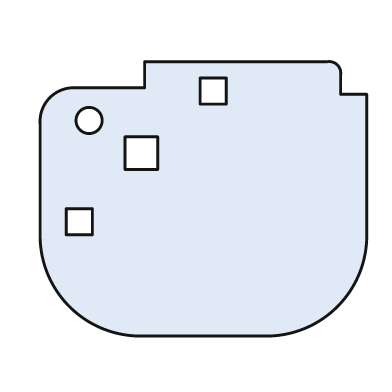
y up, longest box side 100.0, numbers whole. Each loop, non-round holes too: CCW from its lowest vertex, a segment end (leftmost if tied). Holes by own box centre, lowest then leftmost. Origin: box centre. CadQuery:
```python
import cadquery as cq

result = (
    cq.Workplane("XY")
    .moveTo(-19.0, -42.0)
    .lineTo(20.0, -42.0)
    .threePointArc((41.0, -33.0), (50.0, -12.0))
    .lineTo(50.0, 32.0)
    .lineTo(42.0, 32.0)
    .lineTo(42.0, 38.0)
    .threePointArc((41.0, 41.0), (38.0, 42.0))
    .lineTo(-18.0, 42.0)
    .lineTo(-18.0, 34.0)
    .lineTo(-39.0, 34.0)
    .threePointArc((-47.0, 31.0), (-50.0, 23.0))
    .lineTo(-50.0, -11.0)
    .threePointArc((-41.0, -33.0), (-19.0, -42.0))
    .close()
    .moveTo(-42.0, -11.0)
    .lineTo(-34.0, -11.0)
    .lineTo(-34.0, -3.0)
    .lineTo(-42.0, -3.0)
    .close()
    .moveTo(-24.0, 9.0)
    .lineTo(-14.0, 9.0)
    .lineTo(-14.0, 19.0)
    .lineTo(-24.0, 19.0)
    .close()
    .moveTo(-35.0, 24.0)
    .circle(4.0)
    .moveTo(-1.0, 29.0)
    .lineTo(7.0, 29.0)
    .lineTo(7.0, 37.0)
    .lineTo(-1.0, 37.0)
    .close()
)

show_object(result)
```